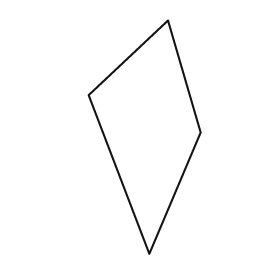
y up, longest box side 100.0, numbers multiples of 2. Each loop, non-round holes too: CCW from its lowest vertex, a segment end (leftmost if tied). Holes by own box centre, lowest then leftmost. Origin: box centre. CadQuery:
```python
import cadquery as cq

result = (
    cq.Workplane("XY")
    .moveTo(2.0, -50.0)
    .lineTo(24.0, 2.0)
    .lineTo(10.0, 50.0)
    .lineTo(-24.0, 18.0)
    .close()
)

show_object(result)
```